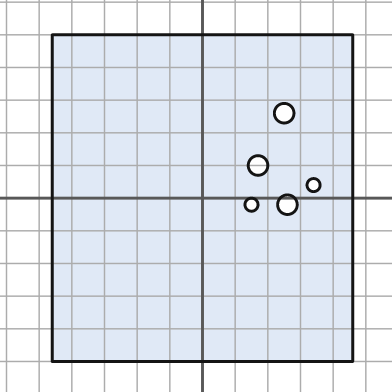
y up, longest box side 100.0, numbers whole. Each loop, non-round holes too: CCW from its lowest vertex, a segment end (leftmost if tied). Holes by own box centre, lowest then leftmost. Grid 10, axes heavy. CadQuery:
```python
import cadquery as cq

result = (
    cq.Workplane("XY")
    .moveTo(-46.0, -50.0)
    .lineTo(46.0, -50.0)
    .lineTo(46.0, 50.0)
    .lineTo(-46.0, 50.0)
    .close()
    .moveTo(15.0, -2.0)
    .circle(2.0)
    .moveTo(26.0, -2.0)
    .circle(3.0)
    .moveTo(34.0, 4.0)
    .circle(2.0)
    .moveTo(17.0, 10.0)
    .circle(3.0)
    .moveTo(25.0, 26.0)
    .circle(3.0)
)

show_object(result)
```